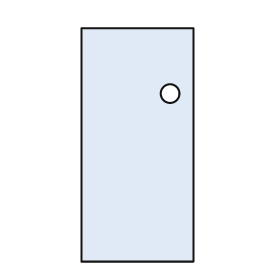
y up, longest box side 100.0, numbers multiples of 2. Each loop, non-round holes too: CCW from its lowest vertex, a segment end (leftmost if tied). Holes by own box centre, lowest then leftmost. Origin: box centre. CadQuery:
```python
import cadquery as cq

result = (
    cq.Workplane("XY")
    .moveTo(-24.0, -50.0)
    .lineTo(24.0, -50.0)
    .lineTo(24.0, 50.0)
    .lineTo(-24.0, 50.0)
    .close()
    .moveTo(14.0, 22.0)
    .circle(4.0)
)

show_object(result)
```